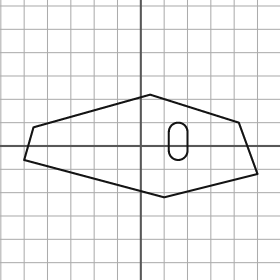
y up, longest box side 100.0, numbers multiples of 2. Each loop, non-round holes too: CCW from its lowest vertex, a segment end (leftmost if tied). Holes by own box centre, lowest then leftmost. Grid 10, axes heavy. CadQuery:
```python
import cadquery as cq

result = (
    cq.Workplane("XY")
    .moveTo(10.0, -22.0)
    .lineTo(50.0, -12.0)
    .lineTo(42.0, 10.0)
    .lineTo(4.0, 22.0)
    .lineTo(-46.0, 8.0)
    .lineTo(-50.0, -6.0)
    .close()
    .moveTo(12.0, -2.0)
    .threePointArc((16.0, -6.0), (20.0, -2.0))
    .lineTo(20.0, 6.0)
    .threePointArc((16.0, 10.0), (12.0, 6.0))
    .close()
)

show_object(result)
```